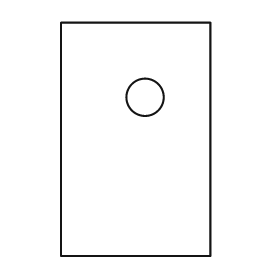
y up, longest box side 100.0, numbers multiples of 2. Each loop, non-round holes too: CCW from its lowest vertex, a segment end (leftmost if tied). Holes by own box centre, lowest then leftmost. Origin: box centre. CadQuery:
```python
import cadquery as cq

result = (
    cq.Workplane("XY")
    .moveTo(-32.0, -50.0)
    .lineTo(32.0, -50.0)
    .lineTo(32.0, 50.0)
    .lineTo(-32.0, 50.0)
    .close()
    .moveTo(4.0, 18.0)
    .circle(8.0)
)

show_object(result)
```